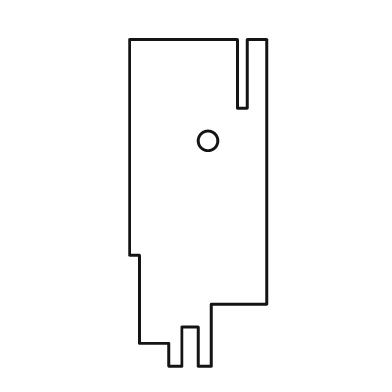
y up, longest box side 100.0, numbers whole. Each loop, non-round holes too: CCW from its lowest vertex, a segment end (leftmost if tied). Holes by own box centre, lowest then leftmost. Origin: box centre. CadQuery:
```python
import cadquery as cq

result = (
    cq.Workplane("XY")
    .moveTo(-9.0, -50.0)
    .lineTo(-5.0, -50.0)
    .lineTo(-5.0, -38.0)
    .lineTo(0.0, -38.0)
    .lineTo(0.0, -50.0)
    .lineTo(4.0, -50.0)
    .lineTo(4.0, -31.0)
    .lineTo(21.0, -31.0)
    .lineTo(21.0, 50.0)
    .lineTo(15.0, 50.0)
    .lineTo(15.0, 29.0)
    .lineTo(12.0, 29.0)
    .lineTo(12.0, 50.0)
    .lineTo(-21.0, 50.0)
    .lineTo(-21.0, -16.0)
    .lineTo(-18.0, -16.0)
    .lineTo(-18.0, -43.0)
    .lineTo(-9.0, -43.0)
    .close()
    .moveTo(3.0, 19.0)
    .circle(3.0)
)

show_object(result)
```